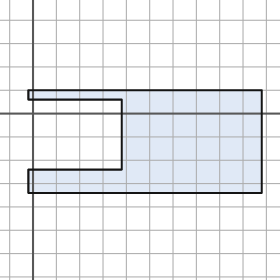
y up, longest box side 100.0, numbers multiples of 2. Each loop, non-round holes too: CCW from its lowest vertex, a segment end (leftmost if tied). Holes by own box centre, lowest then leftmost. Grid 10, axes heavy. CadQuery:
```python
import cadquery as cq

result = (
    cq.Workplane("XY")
    .moveTo(-2.0, -34.0)
    .lineTo(98.0, -34.0)
    .lineTo(98.0, 10.0)
    .lineTo(-2.0, 10.0)
    .lineTo(-2.0, 6.0)
    .lineTo(38.0, 6.0)
    .lineTo(38.0, -24.0)
    .lineTo(-2.0, -24.0)
    .close()
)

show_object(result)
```